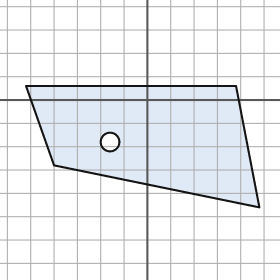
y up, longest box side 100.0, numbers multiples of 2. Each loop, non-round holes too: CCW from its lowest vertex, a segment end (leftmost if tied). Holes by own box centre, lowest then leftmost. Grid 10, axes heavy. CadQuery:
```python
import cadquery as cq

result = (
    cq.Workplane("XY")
    .moveTo(48.0, -46.0)
    .lineTo(38.0, 6.0)
    .lineTo(-52.0, 6.0)
    .lineTo(-40.0, -28.0)
    .close()
    .moveTo(-16.0, -18.0)
    .circle(4.0)
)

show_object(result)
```